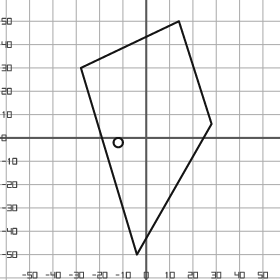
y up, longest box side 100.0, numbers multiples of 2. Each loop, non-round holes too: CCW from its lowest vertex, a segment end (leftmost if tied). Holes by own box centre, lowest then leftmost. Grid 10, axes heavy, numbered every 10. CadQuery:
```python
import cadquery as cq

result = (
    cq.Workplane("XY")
    .moveTo(-4.0, -50.0)
    .lineTo(28.0, 6.0)
    .lineTo(14.0, 50.0)
    .lineTo(-28.0, 30.0)
    .close()
    .moveTo(-12.0, -2.0)
    .circle(2.0)
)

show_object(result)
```